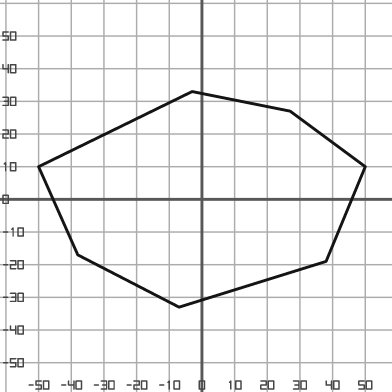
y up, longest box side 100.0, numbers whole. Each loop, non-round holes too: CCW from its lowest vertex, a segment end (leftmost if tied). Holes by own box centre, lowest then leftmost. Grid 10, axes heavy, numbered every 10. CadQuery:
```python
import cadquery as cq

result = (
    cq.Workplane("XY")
    .moveTo(-7.0, -33.0)
    .lineTo(38.0, -19.0)
    .lineTo(50.0, 10.0)
    .lineTo(27.0, 27.0)
    .lineTo(-3.0, 33.0)
    .lineTo(-50.0, 10.0)
    .lineTo(-38.0, -17.0)
    .close()
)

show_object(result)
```